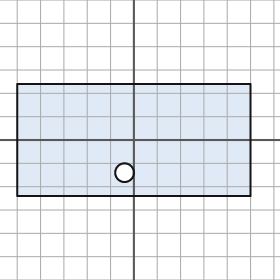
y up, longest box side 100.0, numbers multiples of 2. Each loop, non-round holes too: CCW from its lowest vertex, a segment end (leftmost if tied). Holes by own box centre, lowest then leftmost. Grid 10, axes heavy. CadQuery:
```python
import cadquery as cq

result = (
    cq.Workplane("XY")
    .moveTo(-50.0, -24.0)
    .lineTo(50.0, -24.0)
    .lineTo(50.0, 24.0)
    .lineTo(-50.0, 24.0)
    .close()
    .moveTo(-4.0, -14.0)
    .circle(4.0)
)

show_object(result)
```